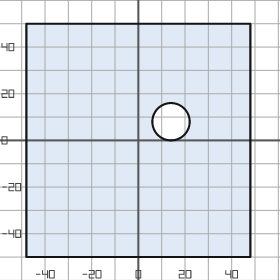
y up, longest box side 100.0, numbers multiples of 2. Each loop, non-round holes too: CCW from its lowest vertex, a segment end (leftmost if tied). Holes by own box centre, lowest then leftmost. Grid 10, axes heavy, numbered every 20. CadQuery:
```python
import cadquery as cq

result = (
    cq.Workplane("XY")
    .moveTo(-48.0, -50.0)
    .lineTo(48.0, -50.0)
    .lineTo(48.0, 50.0)
    .lineTo(-48.0, 50.0)
    .close()
    .moveTo(14.0, 8.0)
    .circle(8.0)
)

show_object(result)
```